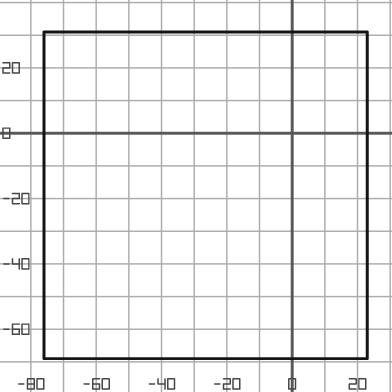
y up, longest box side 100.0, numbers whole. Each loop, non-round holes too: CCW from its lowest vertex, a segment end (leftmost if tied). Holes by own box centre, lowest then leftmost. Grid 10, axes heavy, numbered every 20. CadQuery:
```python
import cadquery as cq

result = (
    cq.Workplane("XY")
    .moveTo(-76.0, -69.0)
    .lineTo(23.0, -69.0)
    .lineTo(23.0, 31.0)
    .lineTo(-76.0, 31.0)
    .close()
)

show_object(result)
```